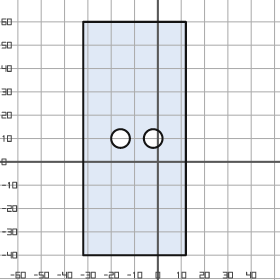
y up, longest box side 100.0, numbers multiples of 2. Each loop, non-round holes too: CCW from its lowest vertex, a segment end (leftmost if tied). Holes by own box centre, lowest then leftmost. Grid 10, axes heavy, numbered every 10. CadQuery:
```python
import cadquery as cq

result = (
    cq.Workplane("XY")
    .moveTo(-32.0, -40.0)
    .lineTo(12.0, -40.0)
    .lineTo(12.0, 60.0)
    .lineTo(-32.0, 60.0)
    .close()
    .moveTo(-16.0, 10.0)
    .circle(4.0)
    .moveTo(-2.0, 10.0)
    .circle(4.0)
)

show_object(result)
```